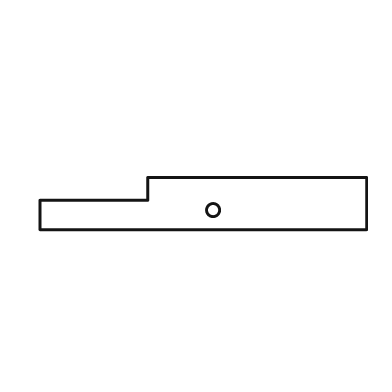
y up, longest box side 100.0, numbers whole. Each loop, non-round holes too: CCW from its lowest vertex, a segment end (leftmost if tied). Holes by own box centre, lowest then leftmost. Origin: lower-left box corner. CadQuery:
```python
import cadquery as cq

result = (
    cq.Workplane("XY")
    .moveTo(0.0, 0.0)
    .lineTo(100.0, 0.0)
    .lineTo(100.0, 16.0)
    .lineTo(33.0, 16.0)
    .lineTo(33.0, 9.0)
    .lineTo(0.0, 9.0)
    .close()
    .moveTo(53.0, 6.0)
    .circle(2.0)
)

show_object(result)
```